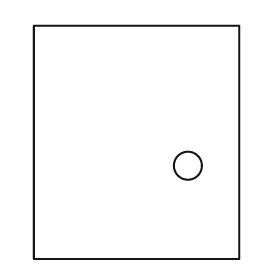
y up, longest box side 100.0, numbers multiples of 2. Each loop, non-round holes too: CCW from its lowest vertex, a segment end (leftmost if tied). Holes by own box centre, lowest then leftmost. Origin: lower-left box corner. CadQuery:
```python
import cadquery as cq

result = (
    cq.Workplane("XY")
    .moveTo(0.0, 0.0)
    .lineTo(88.0, 0.0)
    .lineTo(88.0, 100.0)
    .lineTo(0.0, 100.0)
    .close()
    .moveTo(66.0, 40.0)
    .circle(6.0)
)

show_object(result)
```